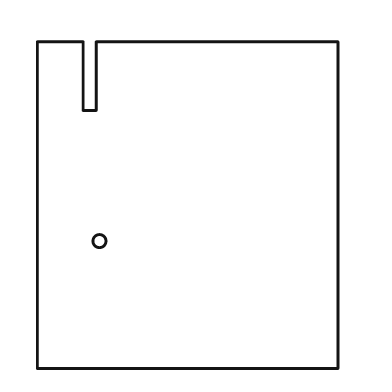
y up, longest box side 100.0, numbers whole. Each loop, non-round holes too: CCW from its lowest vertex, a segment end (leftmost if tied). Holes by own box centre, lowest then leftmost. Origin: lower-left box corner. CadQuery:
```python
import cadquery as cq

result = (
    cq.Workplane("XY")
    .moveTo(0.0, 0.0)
    .lineTo(92.0, 0.0)
    .lineTo(92.0, 100.0)
    .lineTo(18.0, 100.0)
    .lineTo(18.0, 79.0)
    .lineTo(14.0, 79.0)
    .lineTo(14.0, 100.0)
    .lineTo(0.0, 100.0)
    .close()
    .moveTo(19.0, 39.0)
    .circle(2.0)
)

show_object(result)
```